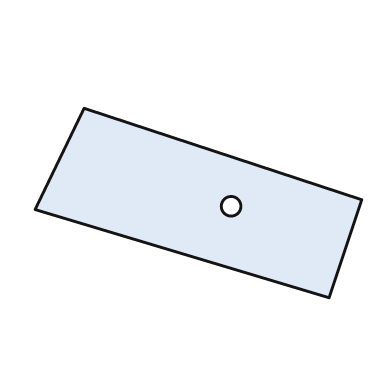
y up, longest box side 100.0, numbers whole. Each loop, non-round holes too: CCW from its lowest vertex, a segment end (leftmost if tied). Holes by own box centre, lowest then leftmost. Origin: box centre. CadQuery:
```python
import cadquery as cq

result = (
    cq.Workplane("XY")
    .moveTo(40.0, -29.0)
    .lineTo(50.0, 1.0)
    .lineTo(-35.0, 29.0)
    .lineTo(-50.0, -2.0)
    .close()
    .moveTo(10.0, -1.0)
    .circle(3.0)
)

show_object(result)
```